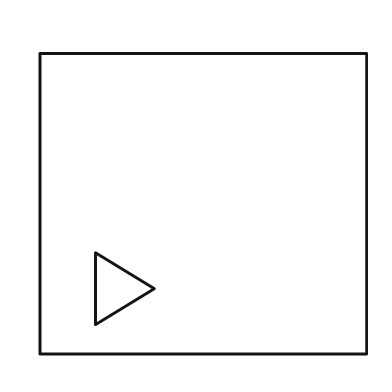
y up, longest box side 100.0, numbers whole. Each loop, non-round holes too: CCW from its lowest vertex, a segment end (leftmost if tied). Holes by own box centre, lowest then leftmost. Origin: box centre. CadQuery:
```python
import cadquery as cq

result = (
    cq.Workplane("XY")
    .moveTo(-50.0, -46.0)
    .lineTo(50.0, -46.0)
    .lineTo(50.0, 46.0)
    .lineTo(-50.0, 46.0)
    .close()
    .moveTo(-33.0, -37.0)
    .lineTo(-15.0, -26.0)
    .lineTo(-33.0, -15.0)
    .close()
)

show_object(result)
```